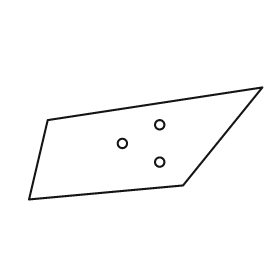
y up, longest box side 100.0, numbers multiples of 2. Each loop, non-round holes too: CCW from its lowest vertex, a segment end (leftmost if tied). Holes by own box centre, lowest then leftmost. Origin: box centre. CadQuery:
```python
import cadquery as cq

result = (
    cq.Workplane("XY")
    .moveTo(-50.0, -24.0)
    .lineTo(16.0, -18.0)
    .lineTo(50.0, 24.0)
    .lineTo(-42.0, 10.0)
    .close()
    .moveTo(6.0, -8.0)
    .circle(2.0)
    .moveTo(-10.0, 0.0)
    .circle(2.0)
    .moveTo(6.0, 8.0)
    .circle(2.0)
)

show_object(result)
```